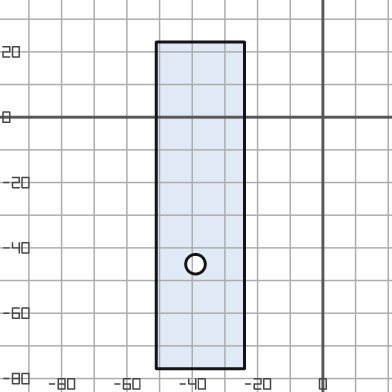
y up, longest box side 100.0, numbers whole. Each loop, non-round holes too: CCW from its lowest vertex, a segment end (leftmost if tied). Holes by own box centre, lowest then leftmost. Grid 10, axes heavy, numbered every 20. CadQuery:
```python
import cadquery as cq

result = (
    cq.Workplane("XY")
    .moveTo(-51.0, -77.0)
    .lineTo(-24.0, -77.0)
    .lineTo(-24.0, 23.0)
    .lineTo(-51.0, 23.0)
    .close()
    .moveTo(-39.0, -45.0)
    .circle(3.0)
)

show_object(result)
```